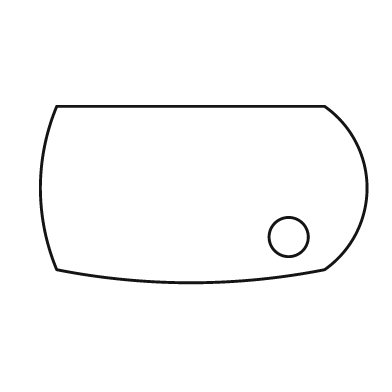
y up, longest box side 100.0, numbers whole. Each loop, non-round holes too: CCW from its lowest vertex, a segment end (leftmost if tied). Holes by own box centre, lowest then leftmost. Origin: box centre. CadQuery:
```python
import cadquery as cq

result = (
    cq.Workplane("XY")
    .moveTo(-45.0, -23.0)
    .threePointArc((-4.0, -27.0), (37.0, -23.0))
    .threePointArc((50.0, 2.0), (37.0, 27.0))
    .lineTo(-45.0, 27.0)
    .threePointArc((-50.0, 2.0), (-45.0, -23.0))
    .close()
    .moveTo(26.0, -13.0)
    .circle(6.0)
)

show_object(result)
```